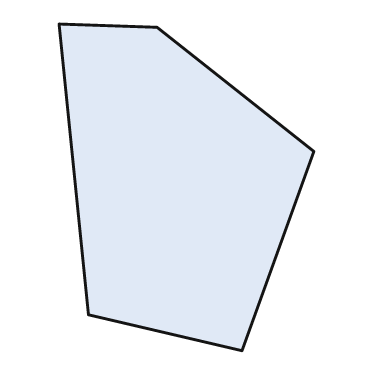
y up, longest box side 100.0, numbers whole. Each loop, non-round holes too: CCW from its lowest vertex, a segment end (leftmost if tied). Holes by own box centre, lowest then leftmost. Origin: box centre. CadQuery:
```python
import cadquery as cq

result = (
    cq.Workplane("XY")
    .moveTo(17.0, -50.0)
    .lineTo(39.0, 11.0)
    .lineTo(-9.0, 49.0)
    .lineTo(-39.0, 50.0)
    .lineTo(-30.0, -39.0)
    .close()
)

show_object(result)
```